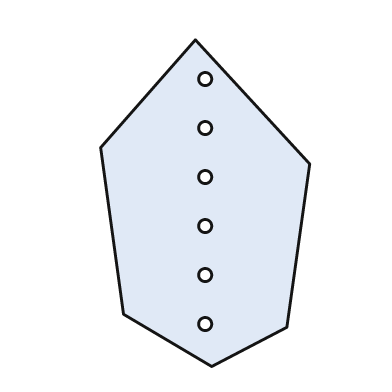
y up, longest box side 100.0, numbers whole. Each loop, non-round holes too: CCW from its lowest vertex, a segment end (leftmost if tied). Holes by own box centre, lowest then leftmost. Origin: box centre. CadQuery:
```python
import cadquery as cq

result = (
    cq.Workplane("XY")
    .moveTo(2.0, -50.0)
    .lineTo(25.0, -38.0)
    .lineTo(32.0, 12.0)
    .lineTo(-3.0, 50.0)
    .lineTo(-32.0, 17.0)
    .lineTo(-25.0, -34.0)
    .close()
    .moveTo(0.0, -37.0)
    .circle(2.0)
    .moveTo(0.0, -22.0)
    .circle(2.0)
    .moveTo(0.0, -7.0)
    .circle(2.0)
    .moveTo(0.0, 8.0)
    .circle(2.0)
    .moveTo(0.0, 23.0)
    .circle(2.0)
    .moveTo(0.0, 38.0)
    .circle(2.0)
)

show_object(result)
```